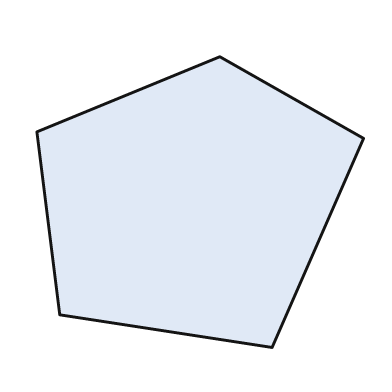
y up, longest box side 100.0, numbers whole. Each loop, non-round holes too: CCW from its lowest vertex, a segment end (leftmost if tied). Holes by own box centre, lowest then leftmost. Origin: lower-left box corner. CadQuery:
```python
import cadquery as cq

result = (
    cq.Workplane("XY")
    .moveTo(72.0, 0.0)
    .lineTo(100.0, 64.0)
    .lineTo(56.0, 89.0)
    .lineTo(0.0, 66.0)
    .lineTo(7.0, 10.0)
    .close()
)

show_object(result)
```